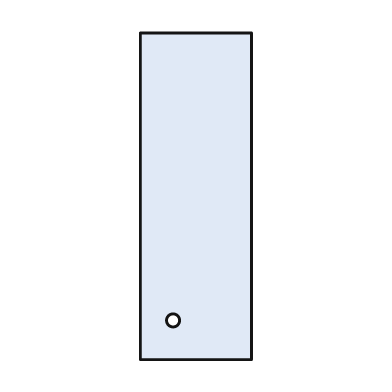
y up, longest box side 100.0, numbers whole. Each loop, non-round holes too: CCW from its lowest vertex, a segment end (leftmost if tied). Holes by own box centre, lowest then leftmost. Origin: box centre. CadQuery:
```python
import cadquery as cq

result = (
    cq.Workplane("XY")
    .moveTo(-17.0, -50.0)
    .lineTo(17.0, -50.0)
    .lineTo(17.0, 50.0)
    .lineTo(-17.0, 50.0)
    .close()
    .moveTo(-7.0, -38.0)
    .circle(2.0)
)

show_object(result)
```